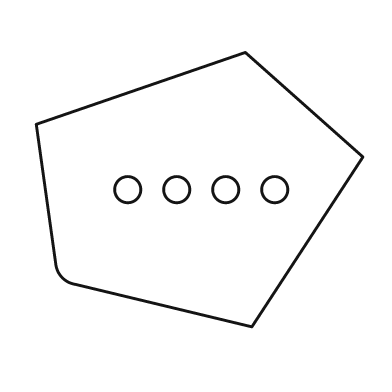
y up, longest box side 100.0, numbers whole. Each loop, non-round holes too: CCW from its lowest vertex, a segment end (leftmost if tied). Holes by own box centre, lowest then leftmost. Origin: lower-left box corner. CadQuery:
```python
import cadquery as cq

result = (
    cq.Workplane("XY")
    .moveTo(66.0, 0.0)
    .lineTo(100.0, 52.0)
    .lineTo(64.0, 84.0)
    .lineTo(0.0, 62.0)
    .lineTo(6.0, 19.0)
    .threePointArc((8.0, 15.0), (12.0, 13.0))
    .close()
    .moveTo(28.0, 42.0)
    .circle(4.0)
    .moveTo(43.0, 42.0)
    .circle(4.0)
    .moveTo(58.0, 42.0)
    .circle(4.0)
    .moveTo(73.0, 42.0)
    .circle(4.0)
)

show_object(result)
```